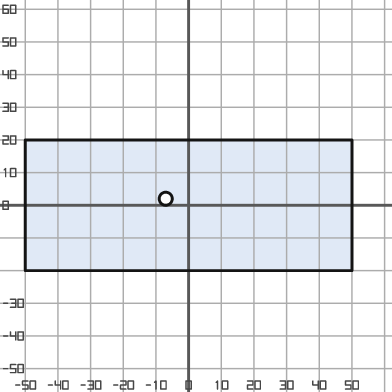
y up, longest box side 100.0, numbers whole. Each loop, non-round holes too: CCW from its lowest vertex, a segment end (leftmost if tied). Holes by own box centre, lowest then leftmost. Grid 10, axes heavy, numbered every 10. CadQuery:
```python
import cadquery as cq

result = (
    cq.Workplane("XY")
    .moveTo(-50.0, -20.0)
    .lineTo(50.0, -20.0)
    .lineTo(50.0, 20.0)
    .lineTo(-50.0, 20.0)
    .close()
    .moveTo(-7.0, 2.0)
    .circle(2.0)
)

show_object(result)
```